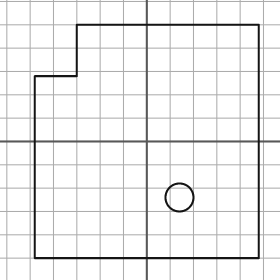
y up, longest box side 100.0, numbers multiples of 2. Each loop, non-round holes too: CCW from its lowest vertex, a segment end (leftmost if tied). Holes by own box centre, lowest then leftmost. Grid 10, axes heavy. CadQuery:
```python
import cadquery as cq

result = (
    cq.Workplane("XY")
    .moveTo(-48.0, -50.0)
    .lineTo(48.0, -50.0)
    .lineTo(48.0, 50.0)
    .lineTo(-30.0, 50.0)
    .lineTo(-30.0, 28.0)
    .lineTo(-48.0, 28.0)
    .close()
    .moveTo(14.0, -24.0)
    .circle(6.0)
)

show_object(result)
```